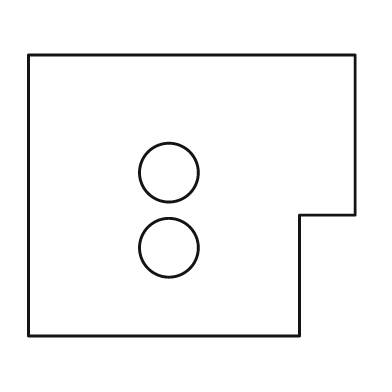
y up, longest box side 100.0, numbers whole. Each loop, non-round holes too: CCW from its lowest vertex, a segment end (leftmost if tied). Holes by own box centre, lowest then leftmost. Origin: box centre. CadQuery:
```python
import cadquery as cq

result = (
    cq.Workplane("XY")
    .moveTo(-50.0, -43.0)
    .lineTo(33.0, -43.0)
    .lineTo(33.0, -6.0)
    .lineTo(50.0, -6.0)
    .lineTo(50.0, 43.0)
    .lineTo(-50.0, 43.0)
    .close()
    .moveTo(-7.0, -16.0)
    .circle(9.0)
    .moveTo(-7.0, 7.0)
    .circle(9.0)
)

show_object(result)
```